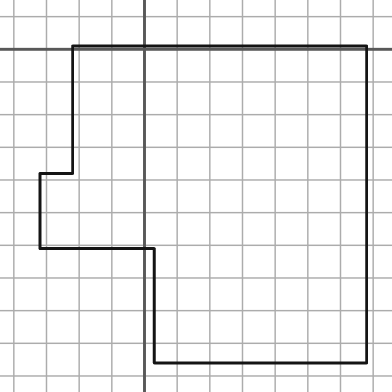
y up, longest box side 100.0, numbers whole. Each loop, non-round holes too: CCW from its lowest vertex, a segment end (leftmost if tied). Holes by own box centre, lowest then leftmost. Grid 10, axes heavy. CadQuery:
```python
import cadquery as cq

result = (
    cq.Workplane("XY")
    .moveTo(3.0, -96.0)
    .lineTo(68.0, -96.0)
    .lineTo(68.0, 1.0)
    .lineTo(-22.0, 1.0)
    .lineTo(-22.0, -38.0)
    .lineTo(-32.0, -38.0)
    .lineTo(-32.0, -61.0)
    .lineTo(3.0, -61.0)
    .close()
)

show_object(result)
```